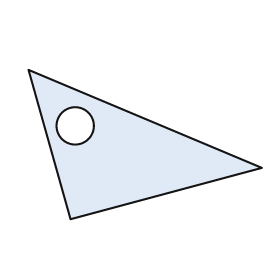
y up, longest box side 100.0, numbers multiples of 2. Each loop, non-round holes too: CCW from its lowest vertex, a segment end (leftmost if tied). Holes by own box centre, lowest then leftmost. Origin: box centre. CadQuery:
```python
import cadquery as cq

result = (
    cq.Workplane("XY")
    .moveTo(-32.0, -32.0)
    .lineTo(50.0, -10.0)
    .lineTo(-50.0, 32.0)
    .close()
    .moveTo(-30.0, 8.0)
    .circle(8.0)
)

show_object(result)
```